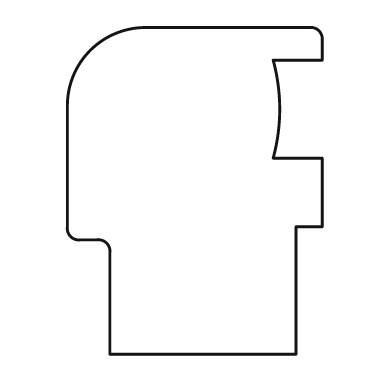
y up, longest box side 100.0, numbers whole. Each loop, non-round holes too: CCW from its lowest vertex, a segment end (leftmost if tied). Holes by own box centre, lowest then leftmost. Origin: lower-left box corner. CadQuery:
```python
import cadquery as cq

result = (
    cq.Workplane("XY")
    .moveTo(13.0, 0.0)
    .lineTo(70.0, 0.0)
    .lineTo(70.0, 39.0)
    .lineTo(78.0, 39.0)
    .lineTo(78.0, 60.0)
    .lineTo(63.0, 60.0)
    .threePointArc((65.0, 75.0), (63.0, 90.0))
    .lineTo(78.0, 90.0)
    .lineTo(78.0, 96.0)
    .threePointArc((77.0, 99.0), (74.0, 100.0))
    .lineTo(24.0, 100.0)
    .threePointArc((7.0, 93.0), (0.0, 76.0))
    .lineTo(0.0, 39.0)
    .threePointArc((1.0, 36.0), (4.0, 35.0))
    .lineTo(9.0, 35.0)
    .threePointArc((12.0, 34.0), (13.0, 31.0))
    .close()
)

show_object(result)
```